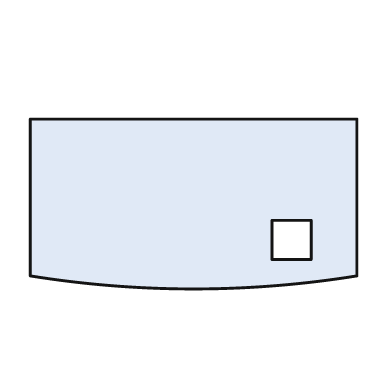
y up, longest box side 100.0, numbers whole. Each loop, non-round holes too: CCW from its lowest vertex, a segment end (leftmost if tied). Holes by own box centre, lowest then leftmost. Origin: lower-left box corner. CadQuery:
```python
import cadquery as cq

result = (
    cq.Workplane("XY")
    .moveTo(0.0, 4.0)
    .threePointArc((50.0, 0.0), (100.0, 4.0))
    .lineTo(100.0, 52.0)
    .lineTo(0.0, 52.0)
    .close()
    .moveTo(74.0, 9.0)
    .lineTo(86.0, 9.0)
    .lineTo(86.0, 21.0)
    .lineTo(74.0, 21.0)
    .close()
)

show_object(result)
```